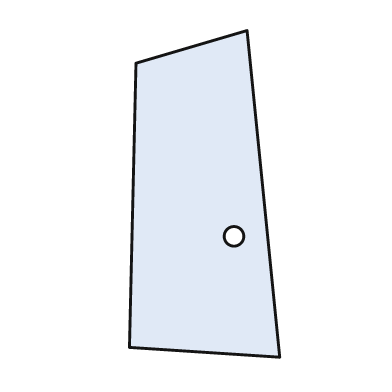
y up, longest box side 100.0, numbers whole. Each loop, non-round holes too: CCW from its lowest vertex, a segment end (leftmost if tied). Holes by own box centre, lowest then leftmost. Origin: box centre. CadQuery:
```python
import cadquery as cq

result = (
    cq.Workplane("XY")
    .moveTo(23.0, -50.0)
    .lineTo(13.0, 50.0)
    .lineTo(-21.0, 40.0)
    .lineTo(-23.0, -47.0)
    .close()
    .moveTo(9.0, -13.0)
    .circle(3.0)
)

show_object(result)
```